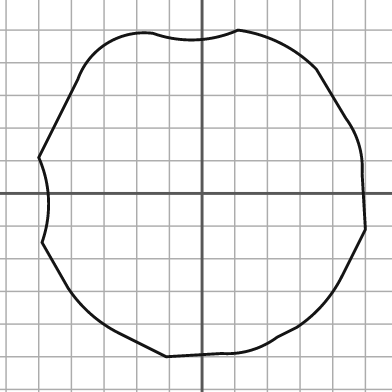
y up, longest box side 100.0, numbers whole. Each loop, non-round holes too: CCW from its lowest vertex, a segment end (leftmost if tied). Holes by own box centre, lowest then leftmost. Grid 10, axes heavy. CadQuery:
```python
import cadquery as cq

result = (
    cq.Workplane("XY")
    .moveTo(-11.0, -50.0)
    .lineTo(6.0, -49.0)
    .threePointArc((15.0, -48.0), (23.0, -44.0))
    .lineTo(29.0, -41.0)
    .threePointArc((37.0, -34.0), (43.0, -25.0))
    .lineTo(50.0, -11.0)
    .lineTo(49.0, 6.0)
    .threePointArc((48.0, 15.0), (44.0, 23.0))
    .lineTo(35.0, 38.0)
    .threePointArc((24.0, 46.0), (11.0, 50.0))
    .threePointArc((-2.0, 47.0), (-15.0, 49.0))
    .threePointArc((-29.0, 46.0), (-38.0, 35.0))
    .lineTo(-50.0, 11.0)
    .threePointArc((-47.0, -2.0), (-49.0, -15.0))
    .lineTo(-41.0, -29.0)
    .threePointArc((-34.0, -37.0), (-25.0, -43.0))
    .close()
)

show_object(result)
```